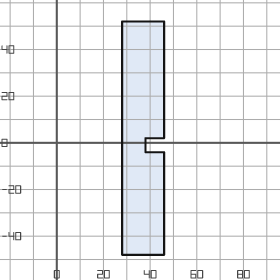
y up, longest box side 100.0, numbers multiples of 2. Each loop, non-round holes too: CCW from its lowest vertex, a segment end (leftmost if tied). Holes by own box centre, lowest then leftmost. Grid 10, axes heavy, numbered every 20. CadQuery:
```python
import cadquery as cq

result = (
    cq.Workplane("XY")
    .moveTo(28.0, -48.0)
    .lineTo(46.0, -48.0)
    .lineTo(46.0, -4.0)
    .lineTo(38.0, -4.0)
    .lineTo(38.0, 2.0)
    .lineTo(46.0, 2.0)
    .lineTo(46.0, 52.0)
    .lineTo(28.0, 52.0)
    .close()
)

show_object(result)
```